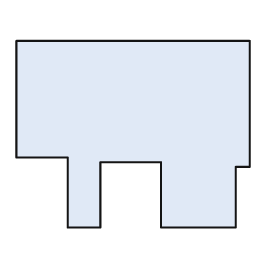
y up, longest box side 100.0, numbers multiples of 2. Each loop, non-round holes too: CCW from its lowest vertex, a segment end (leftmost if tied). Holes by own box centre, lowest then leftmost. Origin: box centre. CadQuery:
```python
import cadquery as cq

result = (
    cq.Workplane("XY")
    .moveTo(-28.0, -40.0)
    .lineTo(-14.0, -40.0)
    .lineTo(-14.0, -12.0)
    .lineTo(12.0, -12.0)
    .lineTo(12.0, -40.0)
    .lineTo(44.0, -40.0)
    .lineTo(44.0, -14.0)
    .lineTo(50.0, -14.0)
    .lineTo(50.0, 40.0)
    .lineTo(-50.0, 40.0)
    .lineTo(-50.0, -10.0)
    .lineTo(-28.0, -10.0)
    .close()
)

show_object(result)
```